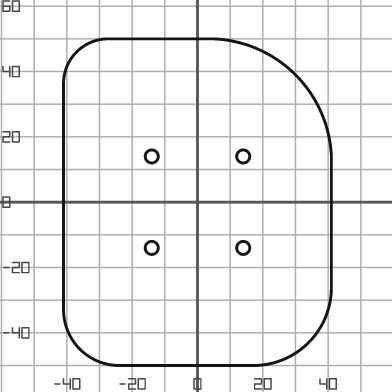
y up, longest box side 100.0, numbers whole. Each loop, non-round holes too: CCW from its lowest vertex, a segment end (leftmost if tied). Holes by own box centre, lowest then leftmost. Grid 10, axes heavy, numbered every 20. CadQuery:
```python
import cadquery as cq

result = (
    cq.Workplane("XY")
    .moveTo(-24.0, -50.0)
    .lineTo(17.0, -50.0)
    .threePointArc((34.0, -43.0), (41.0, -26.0))
    .lineTo(41.0, 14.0)
    .threePointArc((30.0, 39.0), (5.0, 50.0))
    .lineTo(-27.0, 50.0)
    .threePointArc((-37.0, 46.0), (-41.0, 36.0))
    .lineTo(-41.0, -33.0)
    .threePointArc((-36.0, -45.0), (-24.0, -50.0))
    .close()
    .moveTo(-14.0, -14.0)
    .circle(2.0)
    .moveTo(14.0, -14.0)
    .circle(2.0)
    .moveTo(-14.0, 14.0)
    .circle(2.0)
    .moveTo(14.0, 14.0)
    .circle(2.0)
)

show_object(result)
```